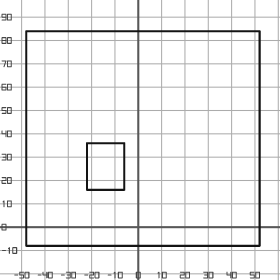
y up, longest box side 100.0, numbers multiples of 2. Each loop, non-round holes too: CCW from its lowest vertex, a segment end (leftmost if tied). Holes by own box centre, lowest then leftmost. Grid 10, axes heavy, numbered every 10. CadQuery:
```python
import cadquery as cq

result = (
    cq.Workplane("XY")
    .moveTo(-48.0, -8.0)
    .lineTo(52.0, -8.0)
    .lineTo(52.0, 84.0)
    .lineTo(-48.0, 84.0)
    .close()
    .moveTo(-22.0, 16.0)
    .lineTo(-6.0, 16.0)
    .lineTo(-6.0, 36.0)
    .lineTo(-22.0, 36.0)
    .close()
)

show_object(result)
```